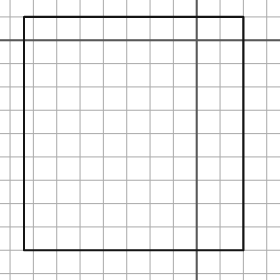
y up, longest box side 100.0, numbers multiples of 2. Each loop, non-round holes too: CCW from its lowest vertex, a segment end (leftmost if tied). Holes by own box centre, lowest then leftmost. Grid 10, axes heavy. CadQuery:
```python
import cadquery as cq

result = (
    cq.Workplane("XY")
    .moveTo(-74.0, -90.0)
    .lineTo(20.0, -90.0)
    .lineTo(20.0, 10.0)
    .lineTo(-74.0, 10.0)
    .close()
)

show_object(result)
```